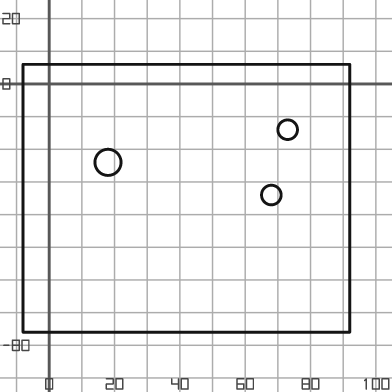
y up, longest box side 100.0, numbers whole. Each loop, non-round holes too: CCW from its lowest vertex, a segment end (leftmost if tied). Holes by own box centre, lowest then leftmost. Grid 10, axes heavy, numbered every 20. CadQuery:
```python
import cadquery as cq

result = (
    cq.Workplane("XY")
    .moveTo(-8.0, -76.0)
    .lineTo(92.0, -76.0)
    .lineTo(92.0, 6.0)
    .lineTo(-8.0, 6.0)
    .close()
    .moveTo(68.0, -34.0)
    .circle(3.0)
    .moveTo(18.0, -24.0)
    .circle(4.0)
    .moveTo(73.0, -14.0)
    .circle(3.0)
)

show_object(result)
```